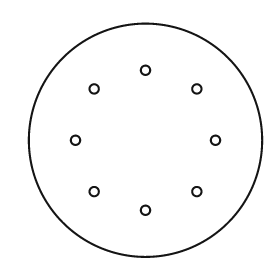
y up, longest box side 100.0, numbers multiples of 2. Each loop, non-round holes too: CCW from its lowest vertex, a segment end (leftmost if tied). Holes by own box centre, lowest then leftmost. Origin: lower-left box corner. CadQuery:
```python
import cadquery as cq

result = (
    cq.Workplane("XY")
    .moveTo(50.0, 50.0)
    .circle(50.0)
    .moveTo(50.0, 20.0)
    .circle(2.0)
    .moveTo(28.0, 28.0)
    .circle(2.0)
    .moveTo(72.0, 28.0)
    .circle(2.0)
    .moveTo(20.0, 50.0)
    .circle(2.0)
    .moveTo(80.0, 50.0)
    .circle(2.0)
    .moveTo(28.0, 72.0)
    .circle(2.0)
    .moveTo(72.0, 72.0)
    .circle(2.0)
    .moveTo(50.0, 80.0)
    .circle(2.0)
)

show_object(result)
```